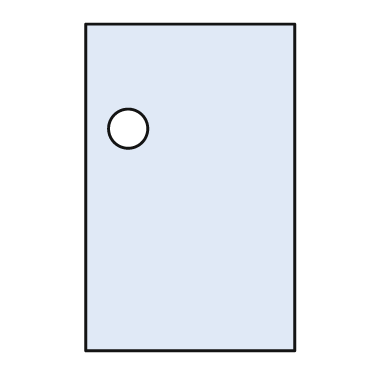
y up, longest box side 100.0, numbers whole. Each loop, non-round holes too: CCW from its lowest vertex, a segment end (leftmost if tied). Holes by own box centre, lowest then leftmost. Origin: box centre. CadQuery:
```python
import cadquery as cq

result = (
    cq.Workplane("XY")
    .moveTo(-32.0, -50.0)
    .lineTo(32.0, -50.0)
    .lineTo(32.0, 50.0)
    .lineTo(-32.0, 50.0)
    .close()
    .moveTo(-19.0, 18.0)
    .circle(6.0)
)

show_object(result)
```